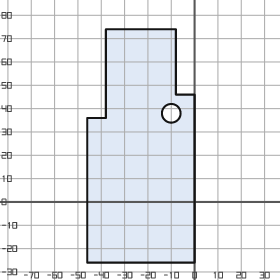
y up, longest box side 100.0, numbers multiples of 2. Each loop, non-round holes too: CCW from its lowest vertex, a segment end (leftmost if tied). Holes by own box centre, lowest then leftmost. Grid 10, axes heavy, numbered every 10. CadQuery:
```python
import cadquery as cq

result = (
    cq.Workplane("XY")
    .moveTo(-46.0, -26.0)
    .lineTo(0.0, -26.0)
    .lineTo(0.0, 46.0)
    .lineTo(-8.0, 46.0)
    .lineTo(-8.0, 74.0)
    .lineTo(-38.0, 74.0)
    .lineTo(-38.0, 36.0)
    .lineTo(-46.0, 36.0)
    .close()
    .moveTo(-10.0, 38.0)
    .circle(4.0)
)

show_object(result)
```